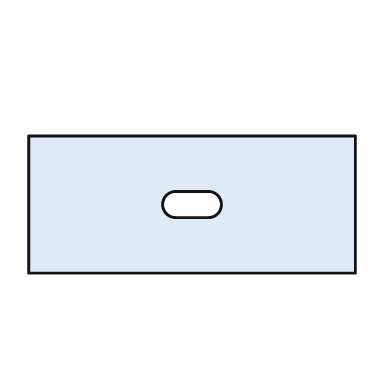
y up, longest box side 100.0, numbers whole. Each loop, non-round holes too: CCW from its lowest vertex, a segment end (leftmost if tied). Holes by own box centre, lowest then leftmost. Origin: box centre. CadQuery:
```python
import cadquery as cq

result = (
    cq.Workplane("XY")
    .moveTo(-50.0, -21.0)
    .lineTo(50.0, -21.0)
    .lineTo(50.0, 21.0)
    .lineTo(-50.0, 21.0)
    .close()
    .moveTo(-5.0, -4.0)
    .lineTo(5.0, -4.0)
    .threePointArc((9.0, 0.0), (5.0, 4.0))
    .lineTo(-5.0, 4.0)
    .threePointArc((-9.0, 0.0), (-5.0, -4.0))
    .close()
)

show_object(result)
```